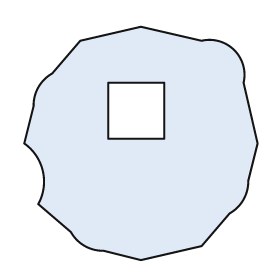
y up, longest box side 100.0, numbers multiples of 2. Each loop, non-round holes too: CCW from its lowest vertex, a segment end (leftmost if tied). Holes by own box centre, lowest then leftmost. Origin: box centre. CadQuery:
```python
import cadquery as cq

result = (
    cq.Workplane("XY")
    .moveTo(0.0, -50.0)
    .lineTo(26.0, -44.0)
    .lineTo(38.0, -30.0)
    .threePointArc((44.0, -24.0), (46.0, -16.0))
    .lineTo(50.0, 0.0)
    .lineTo(44.0, 26.0)
    .threePointArc((40.0, 40.0), (26.0, 44.0))
    .lineTo(0.0, 50.0)
    .lineTo(-26.0, 44.0)
    .lineTo(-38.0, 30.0)
    .threePointArc((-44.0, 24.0), (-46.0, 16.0))
    .lineTo(-50.0, 0.0)
    .threePointArc((-42.0, -12.0), (-44.0, -26.0))
    .lineTo(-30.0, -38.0)
    .threePointArc((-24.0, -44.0), (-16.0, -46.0))
    .close()
    .moveTo(-14.0, 2.0)
    .lineTo(10.0, 2.0)
    .lineTo(10.0, 26.0)
    .lineTo(-14.0, 26.0)
    .close()
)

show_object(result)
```